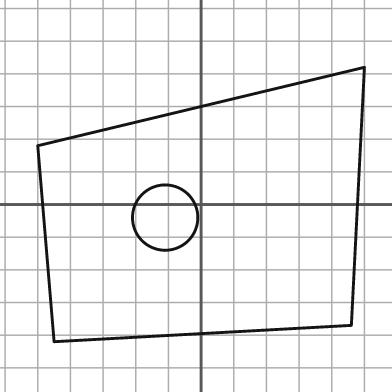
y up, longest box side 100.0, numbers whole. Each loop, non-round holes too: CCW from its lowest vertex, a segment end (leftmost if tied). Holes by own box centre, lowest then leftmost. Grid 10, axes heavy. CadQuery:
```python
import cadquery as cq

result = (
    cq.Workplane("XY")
    .moveTo(-45.0, -42.0)
    .lineTo(46.0, -37.0)
    .lineTo(50.0, 42.0)
    .lineTo(-50.0, 18.0)
    .close()
    .moveTo(-11.0, -4.0)
    .circle(10.0)
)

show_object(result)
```